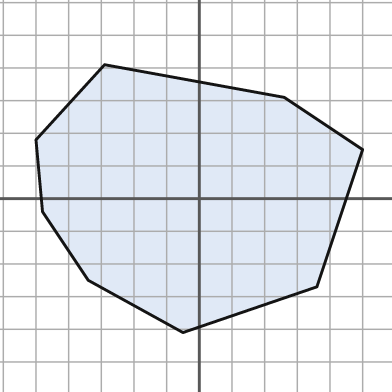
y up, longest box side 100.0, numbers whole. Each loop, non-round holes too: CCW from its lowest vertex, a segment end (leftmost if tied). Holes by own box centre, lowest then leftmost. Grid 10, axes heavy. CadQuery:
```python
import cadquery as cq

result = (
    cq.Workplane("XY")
    .moveTo(-5.0, -41.0)
    .lineTo(36.0, -27.0)
    .lineTo(50.0, 15.0)
    .lineTo(26.0, 31.0)
    .lineTo(-29.0, 41.0)
    .lineTo(-50.0, 18.0)
    .lineTo(-48.0, -4.0)
    .lineTo(-34.0, -25.0)
    .close()
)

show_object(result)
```